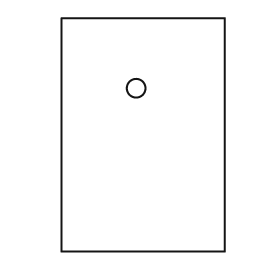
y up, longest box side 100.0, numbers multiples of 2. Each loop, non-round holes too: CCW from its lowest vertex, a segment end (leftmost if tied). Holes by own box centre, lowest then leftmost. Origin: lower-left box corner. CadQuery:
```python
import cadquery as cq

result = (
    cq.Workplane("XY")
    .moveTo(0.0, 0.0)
    .lineTo(70.0, 0.0)
    .lineTo(70.0, 100.0)
    .lineTo(0.0, 100.0)
    .close()
    .moveTo(32.0, 70.0)
    .circle(4.0)
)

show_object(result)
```